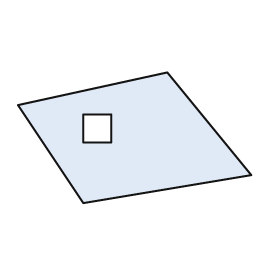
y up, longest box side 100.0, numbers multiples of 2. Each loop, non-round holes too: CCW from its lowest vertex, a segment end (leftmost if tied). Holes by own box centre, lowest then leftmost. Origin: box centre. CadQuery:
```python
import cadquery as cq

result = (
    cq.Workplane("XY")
    .moveTo(-22.0, -28.0)
    .lineTo(50.0, -16.0)
    .lineTo(14.0, 28.0)
    .lineTo(-50.0, 14.0)
    .close()
    .moveTo(-22.0, -2.0)
    .lineTo(-10.0, -2.0)
    .lineTo(-10.0, 10.0)
    .lineTo(-22.0, 10.0)
    .close()
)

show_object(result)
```